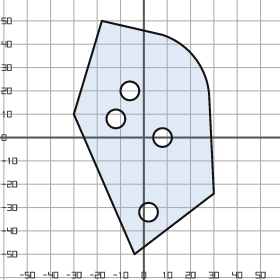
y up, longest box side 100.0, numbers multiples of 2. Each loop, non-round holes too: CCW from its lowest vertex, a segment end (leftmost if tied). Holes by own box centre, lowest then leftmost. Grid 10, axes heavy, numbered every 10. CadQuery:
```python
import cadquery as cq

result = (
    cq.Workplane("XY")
    .moveTo(-4.0, -50.0)
    .lineTo(30.0, -24.0)
    .lineTo(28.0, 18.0)
    .threePointArc((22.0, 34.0), (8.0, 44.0))
    .lineTo(-18.0, 50.0)
    .lineTo(-30.0, 10.0)
    .close()
    .moveTo(2.0, -32.0)
    .circle(4.0)
    .moveTo(8.0, 0.0)
    .circle(4.0)
    .moveTo(-12.0, 8.0)
    .circle(4.0)
    .moveTo(-6.0, 20.0)
    .circle(4.0)
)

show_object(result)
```